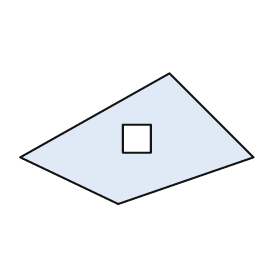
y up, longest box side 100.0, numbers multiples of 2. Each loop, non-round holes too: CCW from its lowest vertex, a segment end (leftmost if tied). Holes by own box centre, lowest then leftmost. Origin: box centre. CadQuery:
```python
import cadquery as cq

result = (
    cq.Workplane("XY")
    .moveTo(-8.0, -28.0)
    .lineTo(50.0, -8.0)
    .lineTo(14.0, 28.0)
    .lineTo(-50.0, -8.0)
    .close()
    .moveTo(-6.0, -6.0)
    .lineTo(6.0, -6.0)
    .lineTo(6.0, 6.0)
    .lineTo(-6.0, 6.0)
    .close()
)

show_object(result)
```